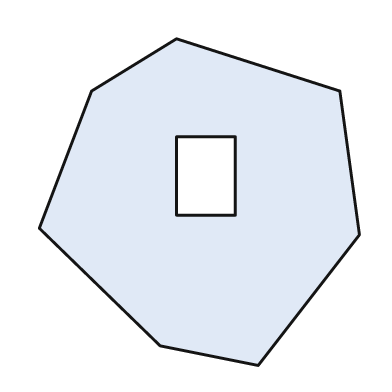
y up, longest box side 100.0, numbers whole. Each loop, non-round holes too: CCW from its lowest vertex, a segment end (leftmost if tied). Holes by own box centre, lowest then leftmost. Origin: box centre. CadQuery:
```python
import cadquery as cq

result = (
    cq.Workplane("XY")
    .moveTo(18.0, -50.0)
    .lineTo(49.0, -10.0)
    .lineTo(43.0, 34.0)
    .lineTo(-7.0, 50.0)
    .lineTo(-33.0, 34.0)
    .lineTo(-49.0, -8.0)
    .lineTo(-12.0, -44.0)
    .close()
    .moveTo(-7.0, -4.0)
    .lineTo(11.0, -4.0)
    .lineTo(11.0, 20.0)
    .lineTo(-7.0, 20.0)
    .close()
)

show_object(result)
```